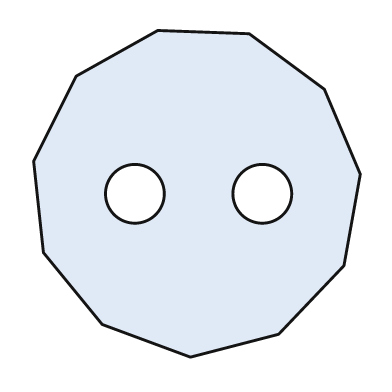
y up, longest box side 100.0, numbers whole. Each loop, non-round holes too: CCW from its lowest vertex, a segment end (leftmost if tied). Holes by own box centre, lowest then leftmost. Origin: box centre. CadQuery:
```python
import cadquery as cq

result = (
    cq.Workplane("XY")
    .moveTo(-2.0, -50.0)
    .lineTo(25.0, -43.0)
    .lineTo(45.0, -22.0)
    .lineTo(50.0, 6.0)
    .lineTo(39.0, 32.0)
    .lineTo(16.0, 49.0)
    .lineTo(-12.0, 50.0)
    .lineTo(-37.0, 36.0)
    .lineTo(-50.0, 10.0)
    .lineTo(-47.0, -18.0)
    .lineTo(-29.0, -40.0)
    .close()
    .moveTo(-19.0, 0.0)
    .circle(9.0)
    .moveTo(20.0, 0.0)
    .circle(9.0)
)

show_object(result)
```